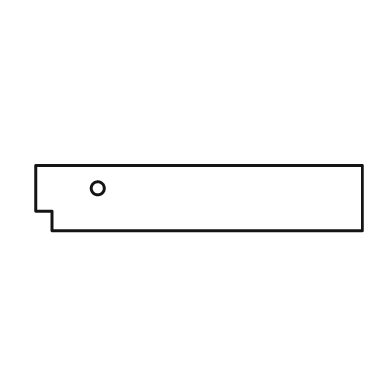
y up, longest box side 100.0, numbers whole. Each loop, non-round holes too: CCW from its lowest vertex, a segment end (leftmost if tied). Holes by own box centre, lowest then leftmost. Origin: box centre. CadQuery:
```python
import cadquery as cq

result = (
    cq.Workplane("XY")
    .moveTo(-45.0, -10.0)
    .lineTo(50.0, -10.0)
    .lineTo(50.0, 10.0)
    .lineTo(-50.0, 10.0)
    .lineTo(-50.0, -4.0)
    .lineTo(-45.0, -4.0)
    .close()
    .moveTo(-31.0, 3.0)
    .circle(2.0)
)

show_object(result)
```